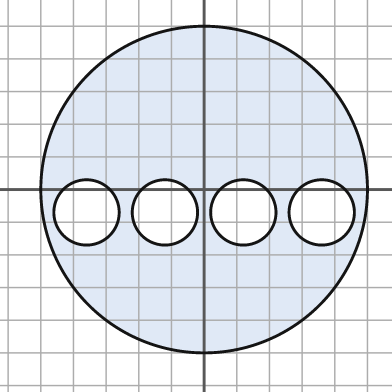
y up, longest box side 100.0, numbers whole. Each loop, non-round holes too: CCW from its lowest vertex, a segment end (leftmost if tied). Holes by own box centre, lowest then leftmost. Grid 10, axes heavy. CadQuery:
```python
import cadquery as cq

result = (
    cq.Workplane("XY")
    .moveTo(0.0, 0.0)
    .circle(50.0)
    .moveTo(-36.0, -7.0)
    .circle(10.0)
    .moveTo(-12.0, -7.0)
    .circle(10.0)
    .moveTo(12.0, -7.0)
    .circle(10.0)
    .moveTo(36.0, -7.0)
    .circle(10.0)
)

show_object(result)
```